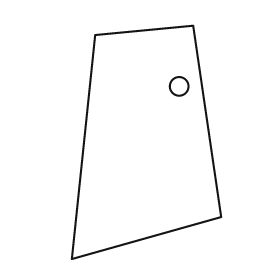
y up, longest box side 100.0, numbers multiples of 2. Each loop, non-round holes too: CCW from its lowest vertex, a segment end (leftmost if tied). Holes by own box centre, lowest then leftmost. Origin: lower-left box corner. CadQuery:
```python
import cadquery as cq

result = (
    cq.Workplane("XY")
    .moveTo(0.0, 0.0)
    .lineTo(64.0, 18.0)
    .lineTo(52.0, 100.0)
    .lineTo(10.0, 96.0)
    .close()
    .moveTo(46.0, 74.0)
    .circle(4.0)
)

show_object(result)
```